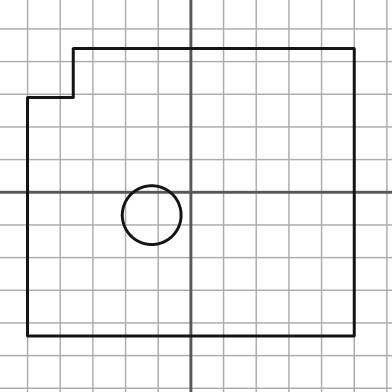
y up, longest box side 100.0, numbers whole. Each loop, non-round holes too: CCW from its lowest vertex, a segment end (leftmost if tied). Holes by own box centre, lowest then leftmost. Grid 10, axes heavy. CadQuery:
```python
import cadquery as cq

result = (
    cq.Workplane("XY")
    .moveTo(-50.0, -44.0)
    .lineTo(50.0, -44.0)
    .lineTo(50.0, 44.0)
    .lineTo(-36.0, 44.0)
    .lineTo(-36.0, 29.0)
    .lineTo(-50.0, 29.0)
    .close()
    .moveTo(-12.0, -7.0)
    .circle(9.0)
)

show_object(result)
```